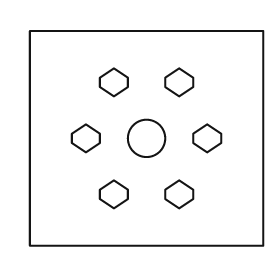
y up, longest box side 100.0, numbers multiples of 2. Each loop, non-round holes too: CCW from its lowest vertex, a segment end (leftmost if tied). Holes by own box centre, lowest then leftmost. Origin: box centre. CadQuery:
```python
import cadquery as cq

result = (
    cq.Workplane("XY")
    .moveTo(-50.0, -46.0)
    .lineTo(50.0, -46.0)
    .lineTo(50.0, 46.0)
    .lineTo(-50.0, 46.0)
    .close()
    .moveTo(-14.0, -30.0)
    .lineTo(-8.0, -26.0)
    .lineTo(-8.0, -22.0)
    .lineTo(-14.0, -18.0)
    .lineTo(-20.0, -22.0)
    .lineTo(-20.0, -26.0)
    .close()
    .moveTo(14.0, -30.0)
    .lineTo(20.0, -26.0)
    .lineTo(20.0, -22.0)
    .lineTo(14.0, -18.0)
    .lineTo(8.0, -22.0)
    .lineTo(8.0, -26.0)
    .close()
    .moveTo(-26.0, -6.0)
    .lineTo(-20.0, -2.0)
    .lineTo(-20.0, 2.0)
    .lineTo(-26.0, 6.0)
    .lineTo(-32.0, 2.0)
    .lineTo(-32.0, -2.0)
    .close()
    .moveTo(0.0, 0.0)
    .circle(8.0)
    .moveTo(26.0, -6.0)
    .lineTo(32.0, -2.0)
    .lineTo(32.0, 2.0)
    .lineTo(26.0, 6.0)
    .lineTo(20.0, 2.0)
    .lineTo(20.0, -2.0)
    .close()
    .moveTo(-14.0, 18.0)
    .lineTo(-8.0, 22.0)
    .lineTo(-8.0, 26.0)
    .lineTo(-14.0, 30.0)
    .lineTo(-20.0, 26.0)
    .lineTo(-20.0, 22.0)
    .close()
    .moveTo(14.0, 18.0)
    .lineTo(20.0, 22.0)
    .lineTo(20.0, 26.0)
    .lineTo(14.0, 30.0)
    .lineTo(8.0, 26.0)
    .lineTo(8.0, 22.0)
    .close()
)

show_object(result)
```